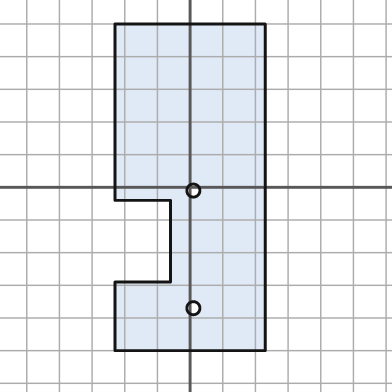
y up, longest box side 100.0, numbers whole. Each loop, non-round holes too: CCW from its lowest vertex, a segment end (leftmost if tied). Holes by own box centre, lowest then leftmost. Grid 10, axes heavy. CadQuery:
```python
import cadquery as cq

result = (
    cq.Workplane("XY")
    .moveTo(-23.0, -50.0)
    .lineTo(23.0, -50.0)
    .lineTo(23.0, 50.0)
    .lineTo(-23.0, 50.0)
    .lineTo(-23.0, -4.0)
    .lineTo(-6.0, -4.0)
    .lineTo(-6.0, -29.0)
    .lineTo(-23.0, -29.0)
    .close()
    .moveTo(1.0, -37.0)
    .circle(2.0)
    .moveTo(1.0, -1.0)
    .circle(2.0)
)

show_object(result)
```